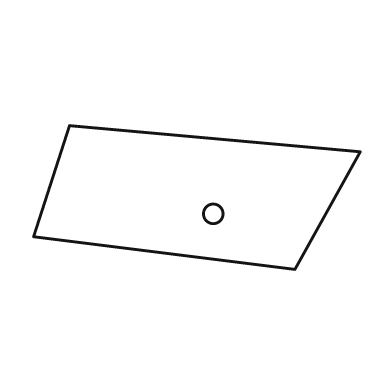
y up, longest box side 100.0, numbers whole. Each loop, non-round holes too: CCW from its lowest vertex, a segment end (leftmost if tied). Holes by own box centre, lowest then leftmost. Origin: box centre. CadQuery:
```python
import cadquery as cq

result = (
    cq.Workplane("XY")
    .moveTo(30.0, -22.0)
    .lineTo(50.0, 14.0)
    .lineTo(-39.0, 22.0)
    .lineTo(-50.0, -12.0)
    .close()
    .moveTo(5.0, -5.0)
    .circle(3.0)
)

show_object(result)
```